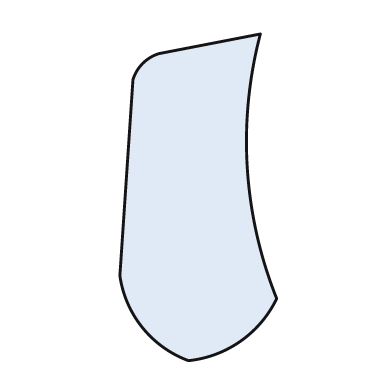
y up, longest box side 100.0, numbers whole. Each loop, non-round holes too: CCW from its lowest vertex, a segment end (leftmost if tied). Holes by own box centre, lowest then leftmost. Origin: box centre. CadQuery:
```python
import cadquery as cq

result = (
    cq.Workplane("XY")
    .moveTo(-3.0, -50.0)
    .threePointArc((13.0, -44.0), (24.0, -31.0))
    .threePointArc((15.0, 9.0), (19.0, 50.0))
    .lineTo(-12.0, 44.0)
    .threePointArc((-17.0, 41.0), (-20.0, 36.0))
    .lineTo(-24.0, -24.0)
    .threePointArc((-17.0, -40.0), (-3.0, -50.0))
    .close()
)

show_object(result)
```